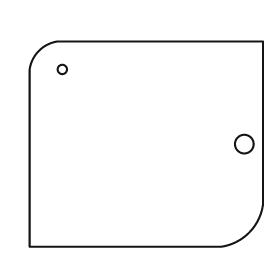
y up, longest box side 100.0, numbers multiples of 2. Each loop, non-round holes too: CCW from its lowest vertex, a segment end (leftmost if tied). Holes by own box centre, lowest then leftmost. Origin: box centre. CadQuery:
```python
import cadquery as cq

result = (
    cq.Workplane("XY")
    .moveTo(-50.0, -44.0)
    .lineTo(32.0, -44.0)
    .threePointArc((44.0, -38.0), (50.0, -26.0))
    .lineTo(50.0, 44.0)
    .lineTo(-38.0, 44.0)
    .threePointArc((-46.0, 40.0), (-50.0, 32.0))
    .close()
    .moveTo(42.0, 0.0)
    .circle(4.0)
    .moveTo(-36.0, 32.0)
    .circle(2.0)
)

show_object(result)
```